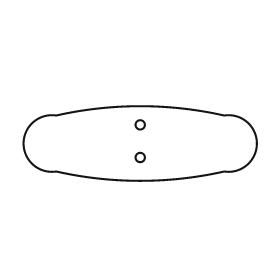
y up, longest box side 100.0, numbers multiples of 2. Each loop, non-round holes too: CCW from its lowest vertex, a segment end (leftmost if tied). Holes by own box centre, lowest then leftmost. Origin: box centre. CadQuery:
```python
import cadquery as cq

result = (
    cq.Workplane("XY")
    .moveTo(-36.0, -12.0)
    .threePointArc((0.0, -16.0), (36.0, -12.0))
    .threePointArc((50.0, 0.0), (36.0, 12.0))
    .threePointArc((0.0, 16.0), (-36.0, 12.0))
    .threePointArc((-50.0, 0.0), (-36.0, -12.0))
    .close()
    .moveTo(0.0, -6.0)
    .circle(2.0)
    .moveTo(0.0, 8.0)
    .circle(2.0)
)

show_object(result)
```